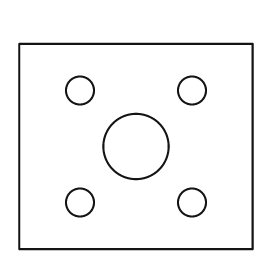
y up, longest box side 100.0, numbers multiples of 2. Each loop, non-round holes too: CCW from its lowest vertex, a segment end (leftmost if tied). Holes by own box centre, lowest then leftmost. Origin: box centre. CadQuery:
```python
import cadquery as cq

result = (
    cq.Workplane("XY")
    .moveTo(-50.0, -44.0)
    .lineTo(50.0, -44.0)
    .lineTo(50.0, 44.0)
    .lineTo(-50.0, 44.0)
    .close()
    .moveTo(-24.0, -24.0)
    .circle(6.0)
    .moveTo(24.0, -24.0)
    .circle(6.0)
    .moveTo(0.0, 0.0)
    .circle(14.0)
    .moveTo(-24.0, 24.0)
    .circle(6.0)
    .moveTo(24.0, 24.0)
    .circle(6.0)
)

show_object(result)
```